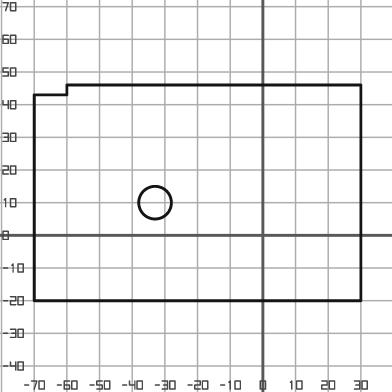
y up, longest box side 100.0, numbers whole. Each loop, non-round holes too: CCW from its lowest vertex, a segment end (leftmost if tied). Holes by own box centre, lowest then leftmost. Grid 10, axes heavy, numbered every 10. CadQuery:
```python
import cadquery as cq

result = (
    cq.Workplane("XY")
    .moveTo(-70.0, -20.0)
    .lineTo(30.0, -20.0)
    .lineTo(30.0, 46.0)
    .lineTo(-60.0, 46.0)
    .lineTo(-60.0, 43.0)
    .lineTo(-70.0, 43.0)
    .close()
    .moveTo(-33.0, 10.0)
    .circle(5.0)
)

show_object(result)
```